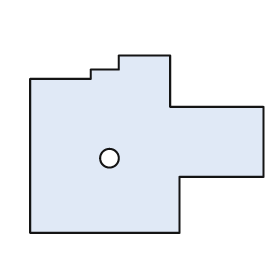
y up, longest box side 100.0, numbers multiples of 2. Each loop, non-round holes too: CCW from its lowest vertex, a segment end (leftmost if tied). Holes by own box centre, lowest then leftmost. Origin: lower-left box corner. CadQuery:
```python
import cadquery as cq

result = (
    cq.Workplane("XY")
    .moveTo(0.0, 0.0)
    .lineTo(64.0, 0.0)
    .lineTo(64.0, 24.0)
    .lineTo(100.0, 24.0)
    .lineTo(100.0, 54.0)
    .lineTo(60.0, 54.0)
    .lineTo(60.0, 76.0)
    .lineTo(38.0, 76.0)
    .lineTo(38.0, 70.0)
    .lineTo(26.0, 70.0)
    .lineTo(26.0, 66.0)
    .lineTo(0.0, 66.0)
    .close()
    .moveTo(34.0, 32.0)
    .circle(4.0)
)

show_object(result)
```